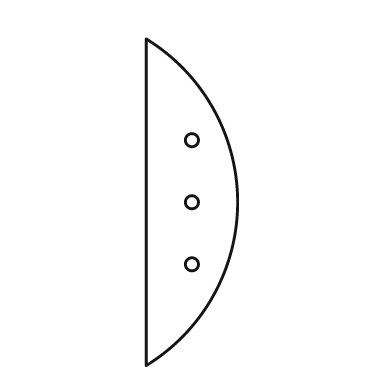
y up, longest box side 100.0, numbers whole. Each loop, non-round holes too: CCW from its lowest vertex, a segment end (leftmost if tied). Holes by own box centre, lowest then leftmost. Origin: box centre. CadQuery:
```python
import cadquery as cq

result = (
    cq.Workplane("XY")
    .moveTo(-14.0, -50.0)
    .threePointArc((14.0, 0.0), (-14.0, 50.0))
    .close()
    .moveTo(0.0, -19.0)
    .circle(2.0)
    .moveTo(0.0, 0.0)
    .circle(2.0)
    .moveTo(0.0, 19.0)
    .circle(2.0)
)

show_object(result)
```